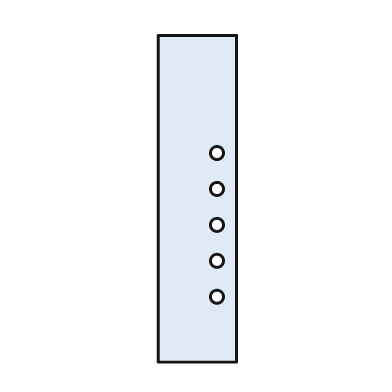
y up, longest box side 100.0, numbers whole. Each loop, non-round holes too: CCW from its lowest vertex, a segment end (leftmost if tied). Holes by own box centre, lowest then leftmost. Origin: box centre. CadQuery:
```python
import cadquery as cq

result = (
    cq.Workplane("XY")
    .moveTo(-12.0, -50.0)
    .lineTo(12.0, -50.0)
    .lineTo(12.0, 50.0)
    .lineTo(-12.0, 50.0)
    .close()
    .moveTo(6.0, -30.0)
    .circle(2.0)
    .moveTo(6.0, -19.0)
    .circle(2.0)
    .moveTo(6.0, -8.0)
    .circle(2.0)
    .moveTo(6.0, 3.0)
    .circle(2.0)
    .moveTo(6.0, 14.0)
    .circle(2.0)
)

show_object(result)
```